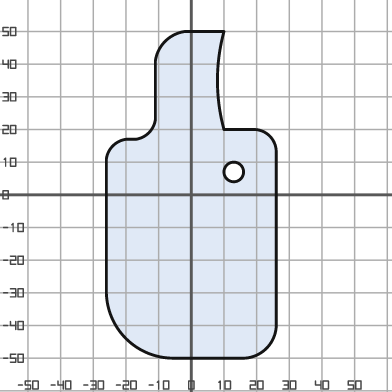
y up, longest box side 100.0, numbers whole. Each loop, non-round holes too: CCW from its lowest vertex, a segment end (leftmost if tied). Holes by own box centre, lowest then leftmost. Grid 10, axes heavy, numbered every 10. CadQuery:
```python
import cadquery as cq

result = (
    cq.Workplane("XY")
    .moveTo(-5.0, -50.0)
    .lineTo(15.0, -50.0)
    .threePointArc((23.0, -47.0), (26.0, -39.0))
    .lineTo(26.0, 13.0)
    .threePointArc((24.0, 18.0), (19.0, 20.0))
    .lineTo(10.0, 20.0)
    .threePointArc((8.0, 35.0), (10.0, 50.0))
    .lineTo(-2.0, 50.0)
    .threePointArc((-8.0, 47.0), (-11.0, 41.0))
    .lineTo(-11.0, 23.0)
    .threePointArc((-13.0, 19.0), (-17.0, 17.0))
    .lineTo(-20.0, 17.0)
    .threePointArc((-24.0, 15.0), (-26.0, 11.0))
    .lineTo(-26.0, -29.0)
    .threePointArc((-20.0, -44.0), (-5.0, -50.0))
    .close()
    .moveTo(13.0, 7.0)
    .circle(3.0)
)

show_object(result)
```